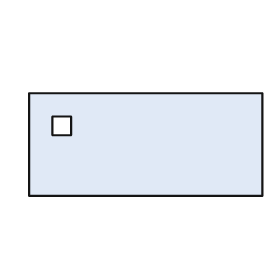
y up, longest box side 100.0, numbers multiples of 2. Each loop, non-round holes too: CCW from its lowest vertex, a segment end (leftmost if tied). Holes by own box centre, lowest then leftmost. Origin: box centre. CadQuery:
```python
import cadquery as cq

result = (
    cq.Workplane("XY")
    .moveTo(-50.0, -22.0)
    .lineTo(50.0, -22.0)
    .lineTo(50.0, 22.0)
    .lineTo(-50.0, 22.0)
    .close()
    .moveTo(-40.0, 4.0)
    .lineTo(-32.0, 4.0)
    .lineTo(-32.0, 12.0)
    .lineTo(-40.0, 12.0)
    .close()
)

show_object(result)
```